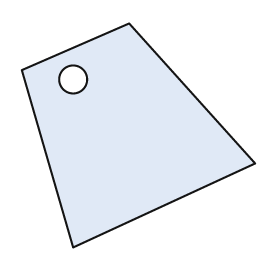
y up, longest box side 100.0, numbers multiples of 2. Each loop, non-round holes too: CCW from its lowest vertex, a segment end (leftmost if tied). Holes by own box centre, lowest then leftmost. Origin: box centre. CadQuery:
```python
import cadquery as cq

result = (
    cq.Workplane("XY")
    .moveTo(-28.0, -48.0)
    .lineTo(50.0, -12.0)
    .lineTo(-4.0, 48.0)
    .lineTo(-50.0, 28.0)
    .close()
    .moveTo(-28.0, 24.0)
    .circle(6.0)
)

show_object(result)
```